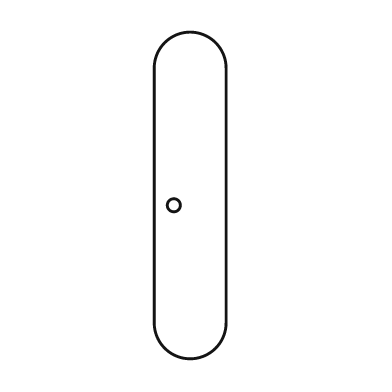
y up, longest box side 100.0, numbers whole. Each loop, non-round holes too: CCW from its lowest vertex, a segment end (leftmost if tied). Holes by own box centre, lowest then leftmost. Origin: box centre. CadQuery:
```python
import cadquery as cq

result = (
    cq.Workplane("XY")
    .moveTo(-11.0, -39.0)
    .threePointArc((0.0, -50.0), (11.0, -39.0))
    .lineTo(11.0, 39.0)
    .threePointArc((0.0, 50.0), (-11.0, 39.0))
    .close()
    .moveTo(-5.0, -3.0)
    .circle(2.0)
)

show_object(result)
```